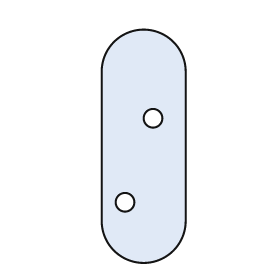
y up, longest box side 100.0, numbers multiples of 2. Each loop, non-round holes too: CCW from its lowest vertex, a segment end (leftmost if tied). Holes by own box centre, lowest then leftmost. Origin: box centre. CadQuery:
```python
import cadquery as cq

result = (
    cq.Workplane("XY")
    .moveTo(-18.0, -32.0)
    .threePointArc((0.0, -50.0), (18.0, -32.0))
    .lineTo(18.0, 32.0)
    .threePointArc((0.0, 50.0), (-18.0, 32.0))
    .close()
    .moveTo(-8.0, -24.0)
    .circle(4.0)
    .moveTo(4.0, 12.0)
    .circle(4.0)
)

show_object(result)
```